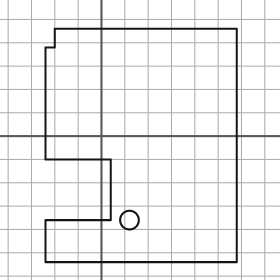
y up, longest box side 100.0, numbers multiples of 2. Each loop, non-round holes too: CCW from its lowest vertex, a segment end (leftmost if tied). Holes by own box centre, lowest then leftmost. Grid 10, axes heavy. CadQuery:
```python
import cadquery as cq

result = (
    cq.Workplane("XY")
    .moveTo(-24.0, -54.0)
    .lineTo(58.0, -54.0)
    .lineTo(58.0, 46.0)
    .lineTo(-20.0, 46.0)
    .lineTo(-20.0, 38.0)
    .lineTo(-24.0, 38.0)
    .lineTo(-24.0, -10.0)
    .lineTo(4.0, -10.0)
    .lineTo(4.0, -36.0)
    .lineTo(-24.0, -36.0)
    .close()
    .moveTo(12.0, -36.0)
    .circle(4.0)
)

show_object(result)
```